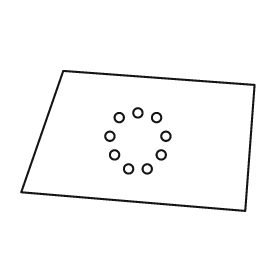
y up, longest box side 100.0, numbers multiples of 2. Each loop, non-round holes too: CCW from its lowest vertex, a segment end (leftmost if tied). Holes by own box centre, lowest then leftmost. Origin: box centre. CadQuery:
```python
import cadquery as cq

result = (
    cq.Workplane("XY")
    .moveTo(46.0, -30.0)
    .lineTo(50.0, 24.0)
    .lineTo(-32.0, 30.0)
    .lineTo(-50.0, -22.0)
    .close()
    .moveTo(-4.0, -12.0)
    .circle(2.0)
    .moveTo(4.0, -12.0)
    .circle(2.0)
    .moveTo(-10.0, -6.0)
    .circle(2.0)
    .moveTo(10.0, -6.0)
    .circle(2.0)
    .moveTo(-12.0, 2.0)
    .circle(2.0)
    .moveTo(12.0, 2.0)
    .circle(2.0)
    .moveTo(-8.0, 10.0)
    .circle(2.0)
    .moveTo(8.0, 10.0)
    .circle(2.0)
    .moveTo(0.0, 12.0)
    .circle(2.0)
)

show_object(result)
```